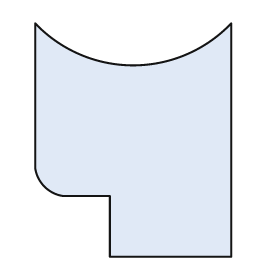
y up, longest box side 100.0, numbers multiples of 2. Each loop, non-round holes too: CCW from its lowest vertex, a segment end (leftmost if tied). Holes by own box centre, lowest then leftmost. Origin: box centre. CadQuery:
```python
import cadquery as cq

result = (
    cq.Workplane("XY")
    .moveTo(-10.0, -50.0)
    .lineTo(42.0, -50.0)
    .lineTo(42.0, 50.0)
    .threePointArc((0.0, 32.0), (-42.0, 50.0))
    .lineTo(-42.0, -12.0)
    .threePointArc((-38.0, -20.0), (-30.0, -24.0))
    .lineTo(-10.0, -24.0)
    .close()
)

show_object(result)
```